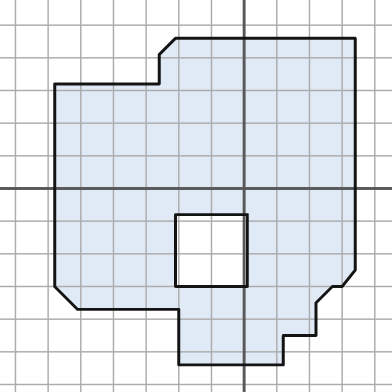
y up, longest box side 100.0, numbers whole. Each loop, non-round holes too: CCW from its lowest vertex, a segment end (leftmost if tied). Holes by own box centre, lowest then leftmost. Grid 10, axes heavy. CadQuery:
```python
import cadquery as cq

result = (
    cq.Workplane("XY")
    .moveTo(-20.0, -54.0)
    .lineTo(12.0, -54.0)
    .lineTo(12.0, -45.0)
    .lineTo(22.0, -45.0)
    .lineTo(22.0, -35.0)
    .lineTo(27.0, -30.0)
    .lineTo(30.0, -30.0)
    .lineTo(34.0, -25.0)
    .lineTo(34.0, 46.0)
    .lineTo(-21.0, 46.0)
    .lineTo(-26.0, 41.0)
    .lineTo(-26.0, 32.0)
    .lineTo(-58.0, 32.0)
    .lineTo(-58.0, -30.0)
    .lineTo(-51.0, -37.0)
    .lineTo(-20.0, -37.0)
    .close()
    .moveTo(-21.0, -30.0)
    .lineTo(1.0, -30.0)
    .lineTo(1.0, -8.0)
    .lineTo(-21.0, -8.0)
    .close()
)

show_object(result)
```